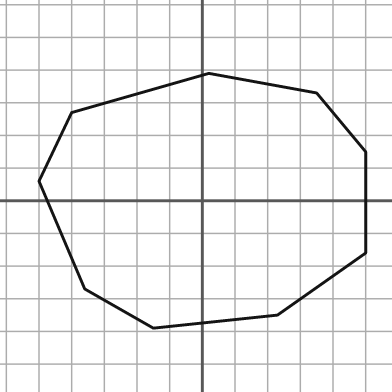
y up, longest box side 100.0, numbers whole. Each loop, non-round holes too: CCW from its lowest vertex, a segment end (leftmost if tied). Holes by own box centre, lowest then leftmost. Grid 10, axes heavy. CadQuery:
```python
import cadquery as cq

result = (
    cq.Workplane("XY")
    .moveTo(-15.0, -39.0)
    .lineTo(23.0, -35.0)
    .lineTo(50.0, -16.0)
    .lineTo(50.0, 15.0)
    .lineTo(35.0, 33.0)
    .lineTo(2.0, 39.0)
    .lineTo(-40.0, 27.0)
    .lineTo(-50.0, 6.0)
    .lineTo(-36.0, -27.0)
    .close()
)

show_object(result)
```